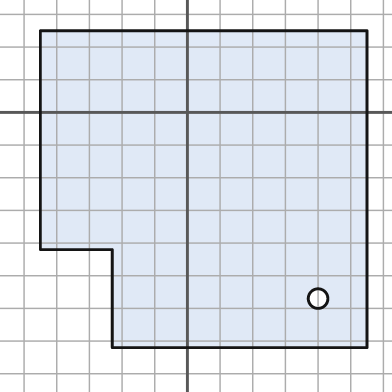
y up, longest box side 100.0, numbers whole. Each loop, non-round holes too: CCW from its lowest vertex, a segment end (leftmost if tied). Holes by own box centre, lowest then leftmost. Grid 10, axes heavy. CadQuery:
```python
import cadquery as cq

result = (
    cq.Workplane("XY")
    .moveTo(-23.0, -72.0)
    .lineTo(55.0, -72.0)
    .lineTo(55.0, 25.0)
    .lineTo(-45.0, 25.0)
    .lineTo(-45.0, -42.0)
    .lineTo(-23.0, -42.0)
    .close()
    .moveTo(40.0, -57.0)
    .circle(3.0)
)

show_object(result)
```